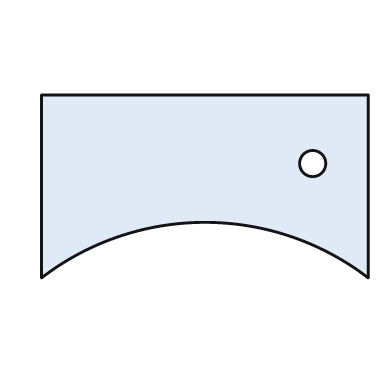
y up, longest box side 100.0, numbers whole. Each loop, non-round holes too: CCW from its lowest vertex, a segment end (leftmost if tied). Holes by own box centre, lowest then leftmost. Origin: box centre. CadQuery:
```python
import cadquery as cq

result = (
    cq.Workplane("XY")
    .moveTo(-50.0, -28.0)
    .threePointArc((0.0, -11.0), (50.0, -28.0))
    .lineTo(50.0, 28.0)
    .lineTo(-50.0, 28.0)
    .close()
    .moveTo(33.0, 7.0)
    .circle(4.0)
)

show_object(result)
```